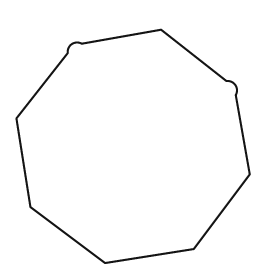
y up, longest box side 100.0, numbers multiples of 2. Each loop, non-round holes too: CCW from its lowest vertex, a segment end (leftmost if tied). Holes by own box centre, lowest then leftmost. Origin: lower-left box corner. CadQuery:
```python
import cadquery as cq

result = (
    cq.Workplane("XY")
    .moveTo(38.0, 0.0)
    .lineTo(76.0, 6.0)
    .lineTo(100.0, 38.0)
    .lineTo(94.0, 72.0)
    .threePointArc((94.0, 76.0), (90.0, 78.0))
    .lineTo(62.0, 100.0)
    .lineTo(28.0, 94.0)
    .threePointArc((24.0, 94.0), (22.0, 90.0))
    .lineTo(0.0, 62.0)
    .lineTo(6.0, 24.0)
    .close()
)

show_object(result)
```